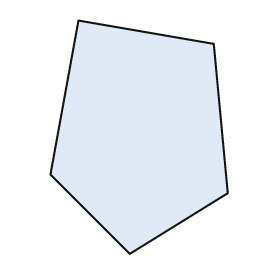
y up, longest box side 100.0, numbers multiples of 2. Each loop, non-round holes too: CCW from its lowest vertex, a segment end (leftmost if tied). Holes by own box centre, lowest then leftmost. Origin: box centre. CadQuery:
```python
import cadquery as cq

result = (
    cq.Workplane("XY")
    .moveTo(-4.0, -50.0)
    .lineTo(38.0, -24.0)
    .lineTo(32.0, 40.0)
    .lineTo(-26.0, 50.0)
    .lineTo(-38.0, -16.0)
    .close()
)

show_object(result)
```